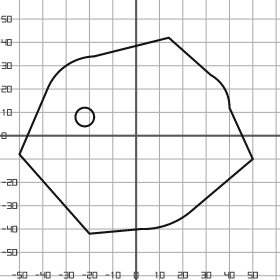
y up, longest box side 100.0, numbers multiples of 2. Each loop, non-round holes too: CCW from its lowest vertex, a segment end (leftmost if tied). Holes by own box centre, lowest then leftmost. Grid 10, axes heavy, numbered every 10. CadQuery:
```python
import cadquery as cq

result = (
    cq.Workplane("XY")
    .moveTo(-20.0, -42.0)
    .lineTo(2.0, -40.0)
    .threePointArc((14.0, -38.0), (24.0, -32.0))
    .lineTo(50.0, -10.0)
    .lineTo(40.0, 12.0)
    .threePointArc((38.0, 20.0), (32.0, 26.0))
    .lineTo(14.0, 42.0)
    .lineTo(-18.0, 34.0)
    .threePointArc((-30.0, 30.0), (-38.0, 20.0))
    .lineTo(-50.0, -8.0)
    .close()
    .moveTo(-22.0, 8.0)
    .circle(4.0)
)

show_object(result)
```